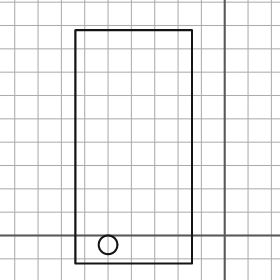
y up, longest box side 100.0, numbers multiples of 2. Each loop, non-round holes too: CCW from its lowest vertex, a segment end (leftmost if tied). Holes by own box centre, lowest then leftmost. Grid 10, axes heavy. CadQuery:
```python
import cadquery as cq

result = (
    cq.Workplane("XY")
    .moveTo(-64.0, -12.0)
    .lineTo(-14.0, -12.0)
    .lineTo(-14.0, 88.0)
    .lineTo(-64.0, 88.0)
    .close()
    .moveTo(-50.0, -4.0)
    .circle(4.0)
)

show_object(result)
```